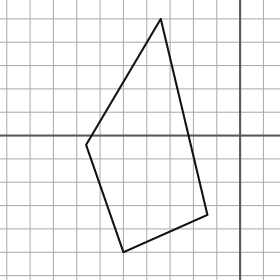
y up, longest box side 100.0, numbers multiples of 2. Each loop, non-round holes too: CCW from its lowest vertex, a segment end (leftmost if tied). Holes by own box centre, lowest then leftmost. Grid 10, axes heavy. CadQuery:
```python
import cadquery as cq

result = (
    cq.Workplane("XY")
    .moveTo(-50.0, -50.0)
    .lineTo(-14.0, -34.0)
    .lineTo(-34.0, 50.0)
    .lineTo(-66.0, -4.0)
    .close()
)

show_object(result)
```